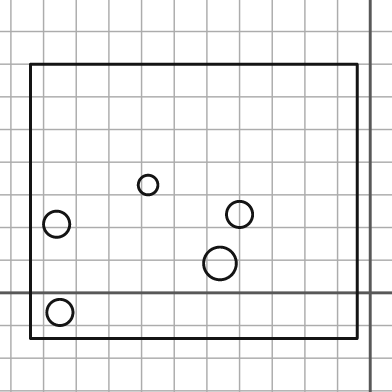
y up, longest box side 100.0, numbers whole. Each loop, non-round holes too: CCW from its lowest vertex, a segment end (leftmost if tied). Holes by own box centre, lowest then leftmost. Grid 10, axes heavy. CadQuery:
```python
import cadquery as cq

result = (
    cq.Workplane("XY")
    .moveTo(-104.0, -14.0)
    .lineTo(-4.0, -14.0)
    .lineTo(-4.0, 70.0)
    .lineTo(-104.0, 70.0)
    .close()
    .moveTo(-95.0, -6.0)
    .circle(4.0)
    .moveTo(-46.0, 9.0)
    .circle(5.0)
    .moveTo(-96.0, 21.0)
    .circle(4.0)
    .moveTo(-40.0, 24.0)
    .circle(4.0)
    .moveTo(-68.0, 33.0)
    .circle(3.0)
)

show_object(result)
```